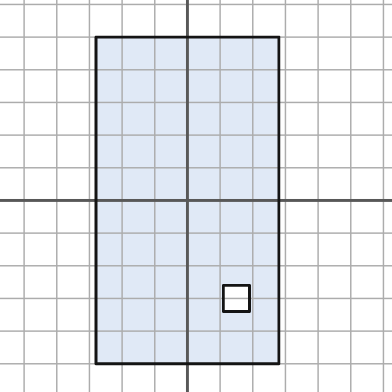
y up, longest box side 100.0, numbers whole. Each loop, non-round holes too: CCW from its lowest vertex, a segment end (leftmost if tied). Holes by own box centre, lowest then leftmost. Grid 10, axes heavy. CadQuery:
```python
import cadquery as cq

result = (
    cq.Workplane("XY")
    .moveTo(-28.0, -50.0)
    .lineTo(28.0, -50.0)
    .lineTo(28.0, 50.0)
    .lineTo(-28.0, 50.0)
    .close()
    .moveTo(11.0, -34.0)
    .lineTo(19.0, -34.0)
    .lineTo(19.0, -26.0)
    .lineTo(11.0, -26.0)
    .close()
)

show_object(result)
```